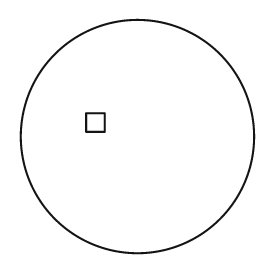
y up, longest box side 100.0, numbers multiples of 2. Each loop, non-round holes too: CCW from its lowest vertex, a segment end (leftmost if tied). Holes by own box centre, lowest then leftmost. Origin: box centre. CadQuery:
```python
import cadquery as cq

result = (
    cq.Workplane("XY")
    .moveTo(0.0, 0.0)
    .circle(50.0)
    .moveTo(-22.0, 2.0)
    .lineTo(-14.0, 2.0)
    .lineTo(-14.0, 10.0)
    .lineTo(-22.0, 10.0)
    .close()
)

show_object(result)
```